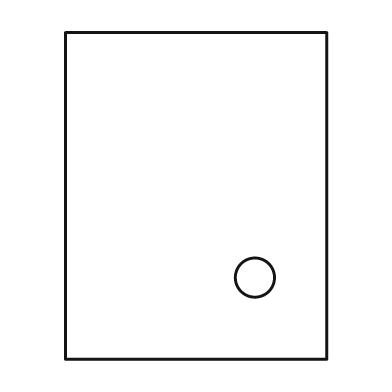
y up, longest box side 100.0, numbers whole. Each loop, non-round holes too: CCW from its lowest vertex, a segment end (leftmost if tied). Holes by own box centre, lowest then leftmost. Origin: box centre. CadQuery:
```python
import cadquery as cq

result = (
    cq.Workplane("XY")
    .moveTo(-40.0, -50.0)
    .lineTo(40.0, -50.0)
    .lineTo(40.0, 50.0)
    .lineTo(-40.0, 50.0)
    .close()
    .moveTo(18.0, -25.0)
    .circle(6.0)
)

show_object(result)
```